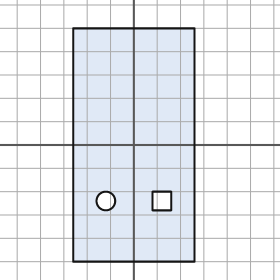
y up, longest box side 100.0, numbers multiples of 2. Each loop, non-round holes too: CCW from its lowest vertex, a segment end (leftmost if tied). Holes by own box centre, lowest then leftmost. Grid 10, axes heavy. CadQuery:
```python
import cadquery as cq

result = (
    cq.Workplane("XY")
    .moveTo(-26.0, -50.0)
    .lineTo(26.0, -50.0)
    .lineTo(26.0, 50.0)
    .lineTo(-26.0, 50.0)
    .close()
    .moveTo(-12.0, -24.0)
    .circle(4.0)
    .moveTo(8.0, -28.0)
    .lineTo(16.0, -28.0)
    .lineTo(16.0, -20.0)
    .lineTo(8.0, -20.0)
    .close()
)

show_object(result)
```